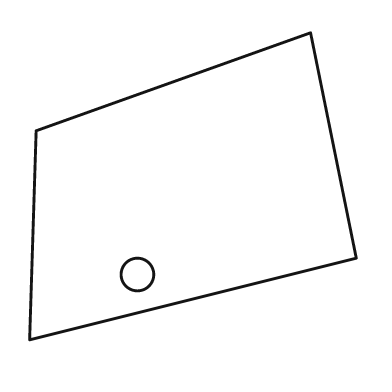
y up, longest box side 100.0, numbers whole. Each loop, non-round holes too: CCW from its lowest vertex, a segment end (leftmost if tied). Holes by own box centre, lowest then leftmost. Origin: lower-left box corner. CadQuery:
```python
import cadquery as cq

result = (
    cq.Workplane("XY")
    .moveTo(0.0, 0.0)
    .lineTo(100.0, 25.0)
    .lineTo(86.0, 94.0)
    .lineTo(2.0, 64.0)
    .close()
    .moveTo(33.0, 20.0)
    .circle(5.0)
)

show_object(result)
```